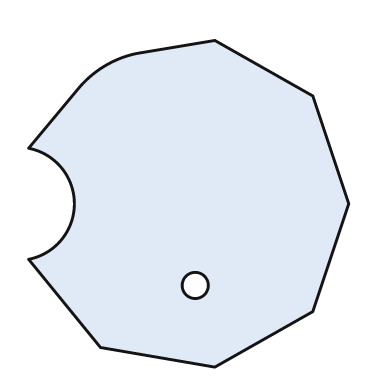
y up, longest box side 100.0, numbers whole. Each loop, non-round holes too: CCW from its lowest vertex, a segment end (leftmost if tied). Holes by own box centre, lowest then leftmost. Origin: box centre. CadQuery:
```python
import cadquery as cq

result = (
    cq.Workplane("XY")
    .moveTo(8.0, -50.0)
    .lineTo(38.0, -33.0)
    .lineTo(49.0, 0.0)
    .lineTo(38.0, 33.0)
    .lineTo(8.0, 50.0)
    .lineTo(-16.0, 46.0)
    .threePointArc((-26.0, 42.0), (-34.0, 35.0))
    .lineTo(-49.0, 17.0)
    .threePointArc((-35.0, 0.0), (-49.0, -17.0))
    .lineTo(-27.0, -44.0)
    .close()
    .moveTo(2.0, -25.0)
    .circle(4.0)
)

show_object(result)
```